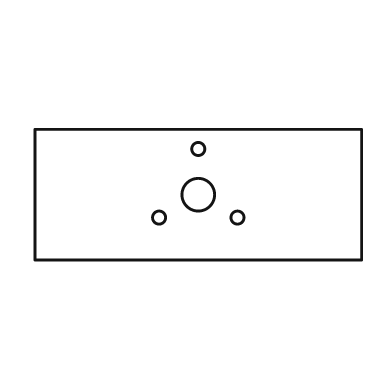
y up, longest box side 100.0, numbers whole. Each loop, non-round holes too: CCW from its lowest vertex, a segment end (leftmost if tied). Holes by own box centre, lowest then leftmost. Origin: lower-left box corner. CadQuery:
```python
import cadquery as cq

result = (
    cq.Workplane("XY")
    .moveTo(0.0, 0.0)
    .lineTo(100.0, 0.0)
    .lineTo(100.0, 40.0)
    .lineTo(0.0, 40.0)
    .close()
    .moveTo(38.0, 13.0)
    .circle(2.0)
    .moveTo(62.0, 13.0)
    .circle(2.0)
    .moveTo(50.0, 20.0)
    .circle(5.0)
    .moveTo(50.0, 34.0)
    .circle(2.0)
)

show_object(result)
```